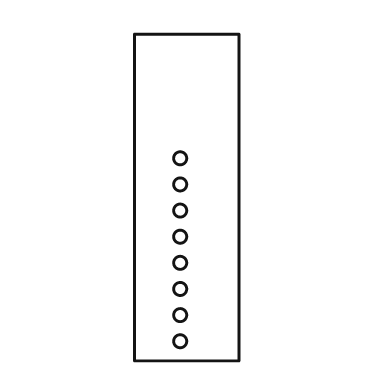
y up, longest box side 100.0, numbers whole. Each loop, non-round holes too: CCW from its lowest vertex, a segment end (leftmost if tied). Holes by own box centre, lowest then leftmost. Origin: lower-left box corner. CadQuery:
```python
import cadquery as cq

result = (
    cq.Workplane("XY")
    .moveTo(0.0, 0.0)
    .lineTo(32.0, 0.0)
    .lineTo(32.0, 100.0)
    .lineTo(0.0, 100.0)
    .close()
    .moveTo(14.0, 6.0)
    .circle(2.0)
    .moveTo(14.0, 14.0)
    .circle(2.0)
    .moveTo(14.0, 22.0)
    .circle(2.0)
    .moveTo(14.0, 30.0)
    .circle(2.0)
    .moveTo(14.0, 38.0)
    .circle(2.0)
    .moveTo(14.0, 46.0)
    .circle(2.0)
    .moveTo(14.0, 54.0)
    .circle(2.0)
    .moveTo(14.0, 62.0)
    .circle(2.0)
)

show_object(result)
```